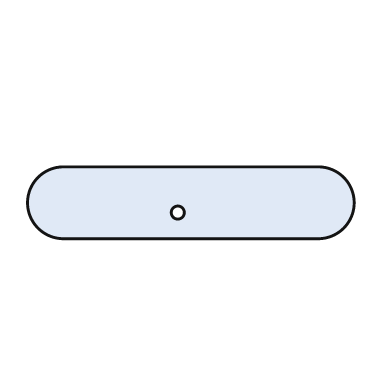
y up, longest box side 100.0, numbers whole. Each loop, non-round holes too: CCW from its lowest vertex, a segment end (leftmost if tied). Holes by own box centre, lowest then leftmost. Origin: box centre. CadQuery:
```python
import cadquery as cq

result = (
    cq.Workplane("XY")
    .moveTo(-39.0, -11.0)
    .lineTo(39.0, -11.0)
    .threePointArc((50.0, 0.0), (39.0, 11.0))
    .lineTo(-39.0, 11.0)
    .threePointArc((-50.0, 0.0), (-39.0, -11.0))
    .close()
    .moveTo(-4.0, -3.0)
    .circle(2.0)
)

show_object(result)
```